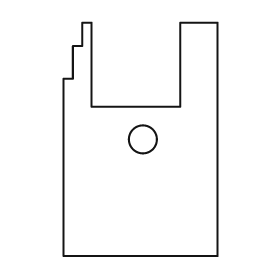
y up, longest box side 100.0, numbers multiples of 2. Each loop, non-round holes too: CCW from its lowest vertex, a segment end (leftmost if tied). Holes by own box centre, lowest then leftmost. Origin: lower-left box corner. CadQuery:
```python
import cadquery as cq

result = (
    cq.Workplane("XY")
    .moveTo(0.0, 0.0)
    .lineTo(66.0, 0.0)
    .lineTo(66.0, 100.0)
    .lineTo(50.0, 100.0)
    .lineTo(50.0, 64.0)
    .lineTo(12.0, 64.0)
    .lineTo(12.0, 100.0)
    .lineTo(8.0, 100.0)
    .lineTo(8.0, 90.0)
    .lineTo(4.0, 90.0)
    .lineTo(4.0, 76.0)
    .lineTo(0.0, 76.0)
    .close()
    .moveTo(34.0, 50.0)
    .circle(6.0)
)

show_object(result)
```